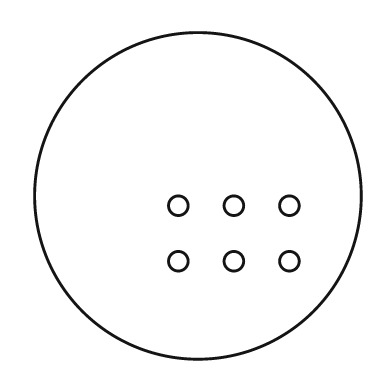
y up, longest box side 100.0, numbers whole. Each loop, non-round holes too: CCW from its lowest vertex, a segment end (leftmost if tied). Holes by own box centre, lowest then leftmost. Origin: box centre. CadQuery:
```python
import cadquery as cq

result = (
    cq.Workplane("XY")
    .moveTo(0.0, 0.0)
    .circle(50.0)
    .moveTo(-6.0, -20.0)
    .circle(3.0)
    .moveTo(11.0, -20.0)
    .circle(3.0)
    .moveTo(28.0, -20.0)
    .circle(3.0)
    .moveTo(-6.0, -3.0)
    .circle(3.0)
    .moveTo(11.0, -3.0)
    .circle(3.0)
    .moveTo(28.0, -3.0)
    .circle(3.0)
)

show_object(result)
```